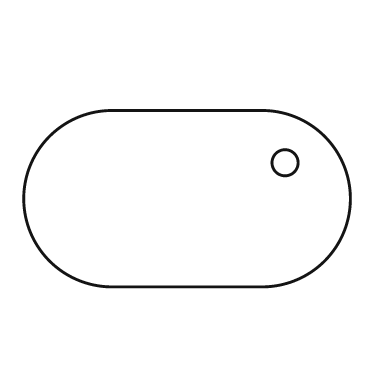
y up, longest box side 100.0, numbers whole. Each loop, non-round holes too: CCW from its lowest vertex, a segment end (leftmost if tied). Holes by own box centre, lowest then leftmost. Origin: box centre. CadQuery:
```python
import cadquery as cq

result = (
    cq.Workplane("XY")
    .moveTo(-23.0, -27.0)
    .lineTo(23.0, -27.0)
    .threePointArc((50.0, 0.0), (23.0, 27.0))
    .lineTo(-23.0, 27.0)
    .threePointArc((-50.0, 0.0), (-23.0, -27.0))
    .close()
    .moveTo(30.0, 11.0)
    .circle(4.0)
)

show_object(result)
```